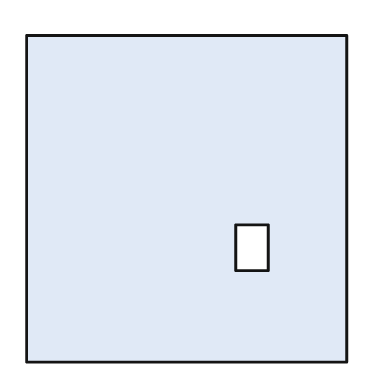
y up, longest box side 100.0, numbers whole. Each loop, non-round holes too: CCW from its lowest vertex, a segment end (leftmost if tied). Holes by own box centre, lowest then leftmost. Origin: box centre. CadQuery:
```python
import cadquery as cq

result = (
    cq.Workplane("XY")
    .moveTo(-49.0, -50.0)
    .lineTo(49.0, -50.0)
    .lineTo(49.0, 50.0)
    .lineTo(-49.0, 50.0)
    .close()
    .moveTo(15.0, -22.0)
    .lineTo(25.0, -22.0)
    .lineTo(25.0, -8.0)
    .lineTo(15.0, -8.0)
    .close()
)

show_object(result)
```